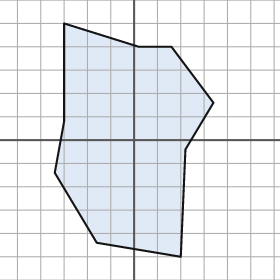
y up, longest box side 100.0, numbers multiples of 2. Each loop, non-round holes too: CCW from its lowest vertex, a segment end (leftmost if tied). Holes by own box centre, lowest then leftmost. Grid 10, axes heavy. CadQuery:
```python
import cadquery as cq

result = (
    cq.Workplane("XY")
    .moveTo(20.0, -50.0)
    .lineTo(22.0, -4.0)
    .lineTo(34.0, 16.0)
    .lineTo(16.0, 40.0)
    .lineTo(2.0, 40.0)
    .lineTo(-30.0, 50.0)
    .lineTo(-30.0, 8.0)
    .lineTo(-34.0, -14.0)
    .lineTo(-16.0, -44.0)
    .close()
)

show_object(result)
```